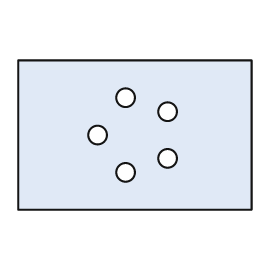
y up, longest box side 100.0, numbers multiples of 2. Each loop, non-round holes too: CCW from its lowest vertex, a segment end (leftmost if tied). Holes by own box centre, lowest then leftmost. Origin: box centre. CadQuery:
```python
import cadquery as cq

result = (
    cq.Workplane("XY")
    .moveTo(-50.0, -32.0)
    .lineTo(50.0, -32.0)
    .lineTo(50.0, 32.0)
    .lineTo(-50.0, 32.0)
    .close()
    .moveTo(-4.0, -16.0)
    .circle(4.0)
    .moveTo(14.0, -10.0)
    .circle(4.0)
    .moveTo(-16.0, 0.0)
    .circle(4.0)
    .moveTo(14.0, 10.0)
    .circle(4.0)
    .moveTo(-4.0, 16.0)
    .circle(4.0)
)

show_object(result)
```